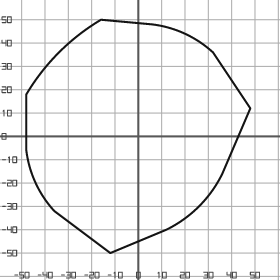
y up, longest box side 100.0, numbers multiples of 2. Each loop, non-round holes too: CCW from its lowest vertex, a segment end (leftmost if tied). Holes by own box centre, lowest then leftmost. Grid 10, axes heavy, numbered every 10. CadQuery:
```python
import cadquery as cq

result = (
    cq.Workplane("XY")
    .moveTo(-12.0, -50.0)
    .lineTo(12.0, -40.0)
    .threePointArc((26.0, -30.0), (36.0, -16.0))
    .lineTo(48.0, 12.0)
    .lineTo(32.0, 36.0)
    .threePointArc((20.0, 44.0), (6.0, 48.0))
    .lineTo(-16.0, 50.0)
    .threePointArc((-34.0, 36.0), (-48.0, 18.0))
    .lineTo(-48.0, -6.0)
    .threePointArc((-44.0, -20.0), (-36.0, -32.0))
    .close()
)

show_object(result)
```